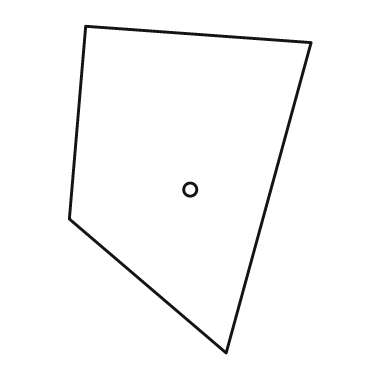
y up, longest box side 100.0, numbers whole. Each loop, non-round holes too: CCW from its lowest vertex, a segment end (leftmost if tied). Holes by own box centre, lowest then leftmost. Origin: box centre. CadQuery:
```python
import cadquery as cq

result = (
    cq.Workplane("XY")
    .moveTo(11.0, -50.0)
    .lineTo(37.0, 45.0)
    .lineTo(-32.0, 50.0)
    .lineTo(-37.0, -9.0)
    .close()
    .moveTo(0.0, 0.0)
    .circle(2.0)
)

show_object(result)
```